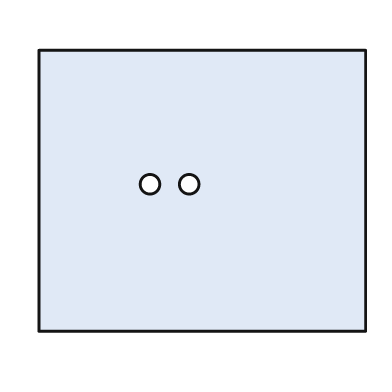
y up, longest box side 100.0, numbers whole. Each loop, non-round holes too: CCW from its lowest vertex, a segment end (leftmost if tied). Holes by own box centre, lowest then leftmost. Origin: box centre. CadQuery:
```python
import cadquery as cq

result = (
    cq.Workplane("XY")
    .moveTo(-50.0, -43.0)
    .lineTo(50.0, -43.0)
    .lineTo(50.0, 43.0)
    .lineTo(-50.0, 43.0)
    .close()
    .moveTo(-16.0, 2.0)
    .circle(3.0)
    .moveTo(-4.0, 2.0)
    .circle(3.0)
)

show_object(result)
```